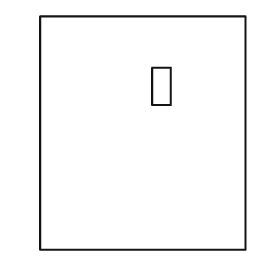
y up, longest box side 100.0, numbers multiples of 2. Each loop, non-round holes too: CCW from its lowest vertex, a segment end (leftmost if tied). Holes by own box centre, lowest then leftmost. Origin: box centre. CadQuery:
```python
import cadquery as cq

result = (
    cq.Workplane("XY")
    .moveTo(-44.0, -50.0)
    .lineTo(44.0, -50.0)
    .lineTo(44.0, 50.0)
    .lineTo(-44.0, 50.0)
    .close()
    .moveTo(4.0, 12.0)
    .lineTo(12.0, 12.0)
    .lineTo(12.0, 28.0)
    .lineTo(4.0, 28.0)
    .close()
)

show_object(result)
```